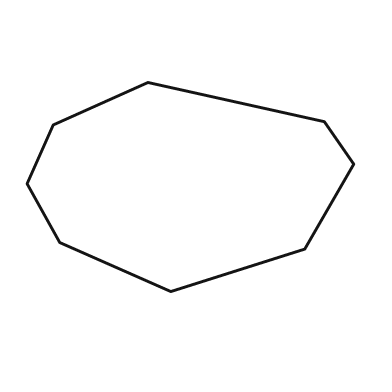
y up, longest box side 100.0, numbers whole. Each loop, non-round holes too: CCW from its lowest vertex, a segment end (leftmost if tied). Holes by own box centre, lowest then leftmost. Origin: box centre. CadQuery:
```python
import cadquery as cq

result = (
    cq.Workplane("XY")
    .moveTo(-6.0, -32.0)
    .lineTo(35.0, -19.0)
    .lineTo(50.0, 7.0)
    .lineTo(41.0, 20.0)
    .lineTo(-13.0, 32.0)
    .lineTo(-42.0, 19.0)
    .lineTo(-50.0, 1.0)
    .lineTo(-40.0, -17.0)
    .close()
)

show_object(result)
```